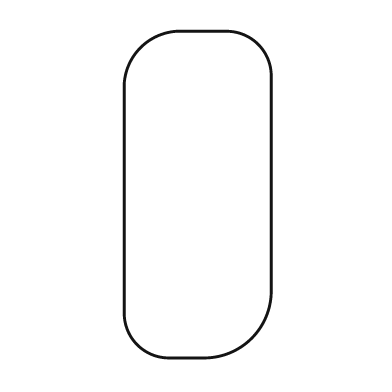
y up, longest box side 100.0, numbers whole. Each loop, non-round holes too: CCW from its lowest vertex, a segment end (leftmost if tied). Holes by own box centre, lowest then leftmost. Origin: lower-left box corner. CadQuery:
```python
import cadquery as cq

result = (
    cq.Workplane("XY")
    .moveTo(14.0, 0.0)
    .lineTo(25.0, 0.0)
    .threePointArc((39.0, 6.0), (45.0, 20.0))
    .lineTo(45.0, 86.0)
    .threePointArc((41.0, 96.0), (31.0, 100.0))
    .lineTo(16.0, 100.0)
    .threePointArc((5.0, 95.0), (0.0, 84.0))
    .lineTo(0.0, 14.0)
    .threePointArc((4.0, 4.0), (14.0, 0.0))
    .close()
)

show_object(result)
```